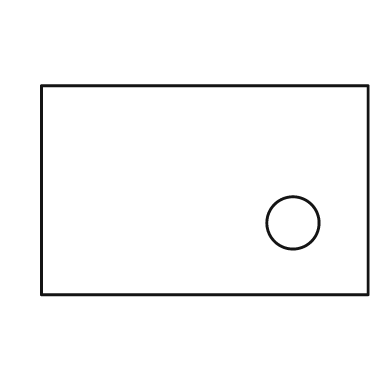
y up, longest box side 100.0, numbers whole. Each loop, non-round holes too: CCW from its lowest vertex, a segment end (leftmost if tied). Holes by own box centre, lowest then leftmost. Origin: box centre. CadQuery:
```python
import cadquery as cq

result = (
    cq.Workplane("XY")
    .moveTo(-50.0, -32.0)
    .lineTo(50.0, -32.0)
    .lineTo(50.0, 32.0)
    .lineTo(-50.0, 32.0)
    .close()
    .moveTo(27.0, -10.0)
    .circle(8.0)
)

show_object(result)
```